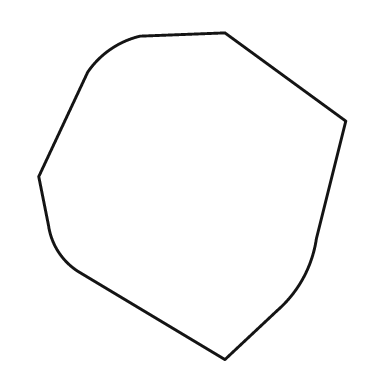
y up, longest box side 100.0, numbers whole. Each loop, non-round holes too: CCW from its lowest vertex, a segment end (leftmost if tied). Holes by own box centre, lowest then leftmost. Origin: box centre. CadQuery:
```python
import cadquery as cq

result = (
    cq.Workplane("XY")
    .moveTo(10.0, -50.0)
    .lineTo(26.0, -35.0)
    .threePointArc((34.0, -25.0), (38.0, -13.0))
    .lineTo(47.0, 23.0)
    .lineTo(10.0, 50.0)
    .lineTo(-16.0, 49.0)
    .threePointArc((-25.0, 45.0), (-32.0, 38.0))
    .lineTo(-47.0, 6.0)
    .lineTo(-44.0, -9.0)
    .threePointArc((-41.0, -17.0), (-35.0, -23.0))
    .close()
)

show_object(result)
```